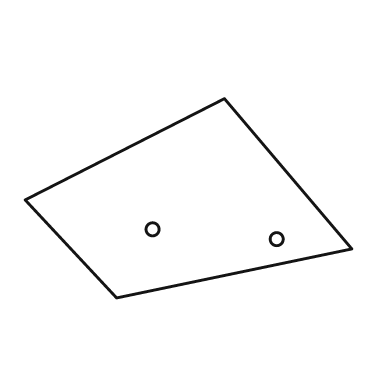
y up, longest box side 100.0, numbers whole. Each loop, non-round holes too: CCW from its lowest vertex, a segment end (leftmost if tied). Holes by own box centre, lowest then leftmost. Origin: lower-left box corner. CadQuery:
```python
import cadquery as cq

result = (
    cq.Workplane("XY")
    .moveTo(28.0, 0.0)
    .lineTo(100.0, 15.0)
    .lineTo(61.0, 61.0)
    .lineTo(0.0, 30.0)
    .close()
    .moveTo(77.0, 18.0)
    .circle(2.0)
    .moveTo(39.0, 21.0)
    .circle(2.0)
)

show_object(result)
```